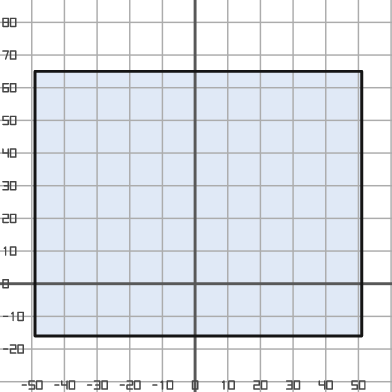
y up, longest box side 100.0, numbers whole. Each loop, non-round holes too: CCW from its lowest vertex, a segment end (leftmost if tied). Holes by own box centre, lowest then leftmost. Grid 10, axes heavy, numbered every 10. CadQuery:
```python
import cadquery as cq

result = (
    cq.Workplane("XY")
    .moveTo(-49.0, -16.0)
    .lineTo(51.0, -16.0)
    .lineTo(51.0, 65.0)
    .lineTo(-49.0, 65.0)
    .close()
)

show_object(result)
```